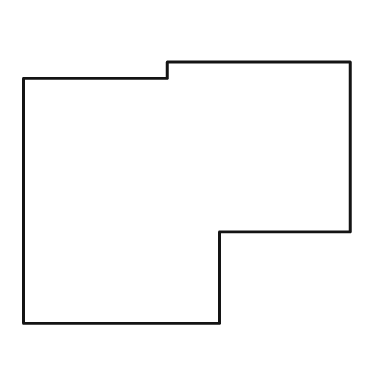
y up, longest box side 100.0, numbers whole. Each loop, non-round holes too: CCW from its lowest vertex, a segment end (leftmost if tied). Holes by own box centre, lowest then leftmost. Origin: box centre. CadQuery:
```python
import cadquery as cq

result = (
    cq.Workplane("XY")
    .moveTo(-50.0, -40.0)
    .lineTo(10.0, -40.0)
    .lineTo(10.0, -12.0)
    .lineTo(50.0, -12.0)
    .lineTo(50.0, 40.0)
    .lineTo(-6.0, 40.0)
    .lineTo(-6.0, 35.0)
    .lineTo(-50.0, 35.0)
    .close()
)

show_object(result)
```